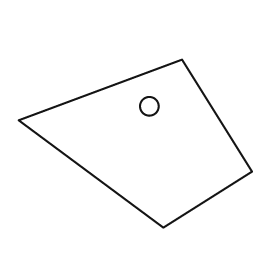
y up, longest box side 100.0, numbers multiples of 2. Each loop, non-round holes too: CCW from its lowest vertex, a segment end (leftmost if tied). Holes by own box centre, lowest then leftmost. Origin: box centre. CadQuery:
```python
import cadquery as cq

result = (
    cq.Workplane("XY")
    .moveTo(12.0, -36.0)
    .lineTo(50.0, -12.0)
    .lineTo(20.0, 36.0)
    .lineTo(-50.0, 10.0)
    .close()
    .moveTo(6.0, 16.0)
    .circle(4.0)
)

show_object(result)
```